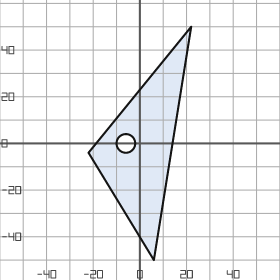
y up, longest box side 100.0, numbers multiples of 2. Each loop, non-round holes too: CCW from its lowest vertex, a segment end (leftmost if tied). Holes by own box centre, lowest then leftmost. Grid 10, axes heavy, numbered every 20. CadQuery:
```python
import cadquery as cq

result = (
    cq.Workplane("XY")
    .moveTo(6.0, -50.0)
    .lineTo(22.0, 50.0)
    .lineTo(-22.0, -4.0)
    .close()
    .moveTo(-6.0, 0.0)
    .circle(4.0)
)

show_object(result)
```